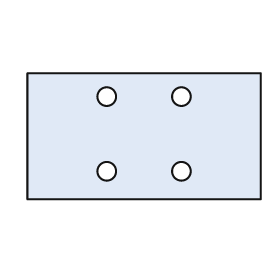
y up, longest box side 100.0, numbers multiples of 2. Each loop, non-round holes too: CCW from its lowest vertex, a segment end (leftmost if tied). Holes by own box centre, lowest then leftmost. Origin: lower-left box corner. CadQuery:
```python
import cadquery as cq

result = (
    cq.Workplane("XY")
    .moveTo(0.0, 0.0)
    .lineTo(100.0, 0.0)
    .lineTo(100.0, 54.0)
    .lineTo(0.0, 54.0)
    .close()
    .moveTo(34.0, 12.0)
    .circle(4.0)
    .moveTo(66.0, 12.0)
    .circle(4.0)
    .moveTo(34.0, 44.0)
    .circle(4.0)
    .moveTo(66.0, 44.0)
    .circle(4.0)
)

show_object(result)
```